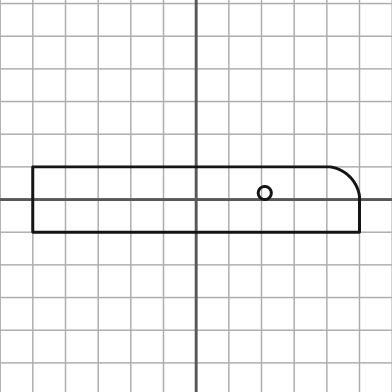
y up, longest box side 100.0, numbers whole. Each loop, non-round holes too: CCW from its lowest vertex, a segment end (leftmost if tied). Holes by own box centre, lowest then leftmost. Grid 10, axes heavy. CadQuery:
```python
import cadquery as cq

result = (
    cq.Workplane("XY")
    .moveTo(-50.0, -10.0)
    .lineTo(50.0, -10.0)
    .lineTo(50.0, 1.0)
    .threePointArc((47.0, 7.0), (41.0, 10.0))
    .lineTo(-50.0, 10.0)
    .close()
    .moveTo(21.0, 2.0)
    .circle(2.0)
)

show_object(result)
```